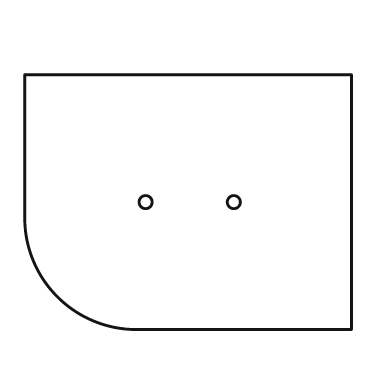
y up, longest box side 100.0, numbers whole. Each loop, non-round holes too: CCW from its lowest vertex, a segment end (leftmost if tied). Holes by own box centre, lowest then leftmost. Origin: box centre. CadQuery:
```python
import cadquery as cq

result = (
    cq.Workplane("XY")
    .moveTo(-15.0, -39.0)
    .lineTo(50.0, -39.0)
    .lineTo(50.0, 39.0)
    .lineTo(-50.0, 39.0)
    .lineTo(-50.0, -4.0)
    .threePointArc((-40.0, -29.0), (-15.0, -39.0))
    .close()
    .moveTo(-13.0, 0.0)
    .circle(2.0)
    .moveTo(14.0, 0.0)
    .circle(2.0)
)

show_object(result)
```